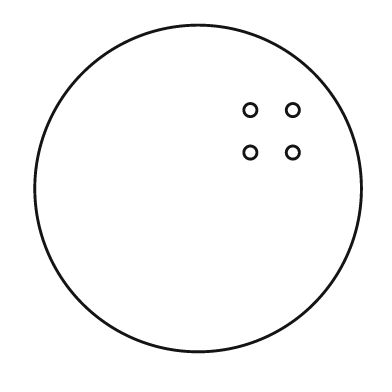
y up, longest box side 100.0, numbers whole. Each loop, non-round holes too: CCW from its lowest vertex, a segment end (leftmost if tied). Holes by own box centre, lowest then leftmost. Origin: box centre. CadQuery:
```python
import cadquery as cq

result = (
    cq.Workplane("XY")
    .moveTo(0.0, 0.0)
    .circle(50.0)
    .moveTo(16.0, 11.0)
    .circle(2.0)
    .moveTo(29.0, 11.0)
    .circle(2.0)
    .moveTo(16.0, 24.0)
    .circle(2.0)
    .moveTo(29.0, 24.0)
    .circle(2.0)
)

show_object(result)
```